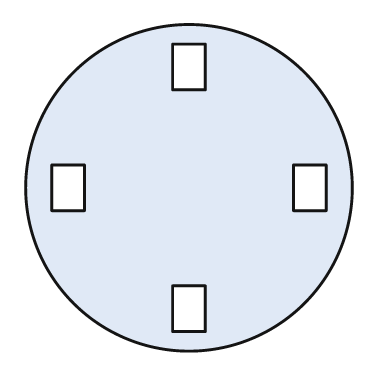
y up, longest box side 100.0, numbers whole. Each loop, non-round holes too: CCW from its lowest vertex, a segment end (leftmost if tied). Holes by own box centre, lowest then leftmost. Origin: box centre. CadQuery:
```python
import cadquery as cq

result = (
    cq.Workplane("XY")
    .moveTo(0.0, 0.0)
    .circle(50.0)
    .moveTo(-5.0, -44.0)
    .lineTo(5.0, -44.0)
    .lineTo(5.0, -30.0)
    .lineTo(-5.0, -30.0)
    .close()
    .moveTo(-42.0, -7.0)
    .lineTo(-32.0, -7.0)
    .lineTo(-32.0, 7.0)
    .lineTo(-42.0, 7.0)
    .close()
    .moveTo(32.0, -7.0)
    .lineTo(42.0, -7.0)
    .lineTo(42.0, 7.0)
    .lineTo(32.0, 7.0)
    .close()
    .moveTo(-5.0, 30.0)
    .lineTo(5.0, 30.0)
    .lineTo(5.0, 44.0)
    .lineTo(-5.0, 44.0)
    .close()
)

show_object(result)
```